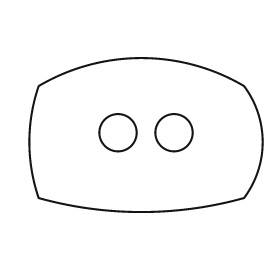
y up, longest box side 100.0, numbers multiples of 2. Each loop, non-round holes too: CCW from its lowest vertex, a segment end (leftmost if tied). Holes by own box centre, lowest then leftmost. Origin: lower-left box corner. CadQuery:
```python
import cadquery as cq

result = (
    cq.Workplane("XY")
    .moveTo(4.0, 6.0)
    .threePointArc((48.0, 0.0), (92.0, 6.0))
    .threePointArc((100.0, 30.0), (92.0, 54.0))
    .threePointArc((48.0, 66.0), (4.0, 54.0))
    .threePointArc((0.0, 30.0), (4.0, 6.0))
    .close()
    .moveTo(38.0, 34.0)
    .circle(8.0)
    .moveTo(62.0, 34.0)
    .circle(8.0)
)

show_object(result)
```